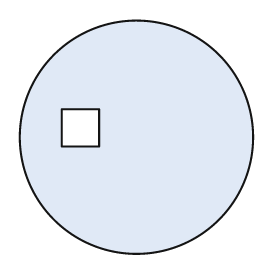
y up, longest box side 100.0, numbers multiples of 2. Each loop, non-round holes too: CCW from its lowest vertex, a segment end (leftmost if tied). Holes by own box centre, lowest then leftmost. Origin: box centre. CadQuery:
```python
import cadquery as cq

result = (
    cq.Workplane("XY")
    .moveTo(0.0, 0.0)
    .circle(50.0)
    .moveTo(-32.0, -4.0)
    .lineTo(-16.0, -4.0)
    .lineTo(-16.0, 12.0)
    .lineTo(-32.0, 12.0)
    .close()
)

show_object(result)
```